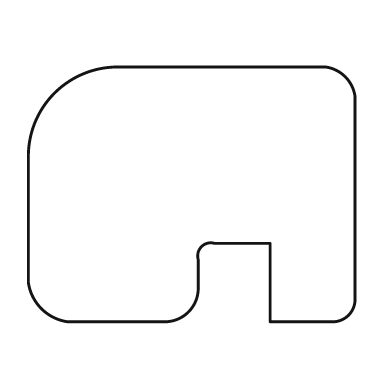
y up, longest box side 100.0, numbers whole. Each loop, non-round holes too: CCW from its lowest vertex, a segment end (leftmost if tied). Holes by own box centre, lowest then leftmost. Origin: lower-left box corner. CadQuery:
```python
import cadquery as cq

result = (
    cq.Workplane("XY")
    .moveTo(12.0, 0.0)
    .lineTo(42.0, 0.0)
    .threePointArc((49.0, 3.0), (52.0, 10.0))
    .lineTo(52.0, 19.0)
    .threePointArc((53.0, 23.0), (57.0, 24.0))
    .lineTo(74.0, 24.0)
    .lineTo(74.0, 0.0)
    .lineTo(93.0, 0.0)
    .threePointArc((98.0, 2.0), (100.0, 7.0))
    .lineTo(100.0, 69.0)
    .threePointArc((97.0, 75.0), (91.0, 78.0))
    .lineTo(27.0, 78.0)
    .threePointArc((8.0, 70.0), (0.0, 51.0))
    .lineTo(0.0, 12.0)
    .threePointArc((4.0, 4.0), (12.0, 0.0))
    .close()
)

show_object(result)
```